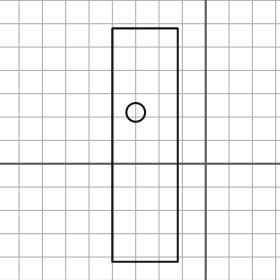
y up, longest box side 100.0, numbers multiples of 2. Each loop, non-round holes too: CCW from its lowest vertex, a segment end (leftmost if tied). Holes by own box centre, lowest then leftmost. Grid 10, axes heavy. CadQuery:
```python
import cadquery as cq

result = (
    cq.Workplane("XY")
    .moveTo(-40.0, -42.0)
    .lineTo(-12.0, -42.0)
    .lineTo(-12.0, 58.0)
    .lineTo(-40.0, 58.0)
    .close()
    .moveTo(-30.0, 22.0)
    .circle(4.0)
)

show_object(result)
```